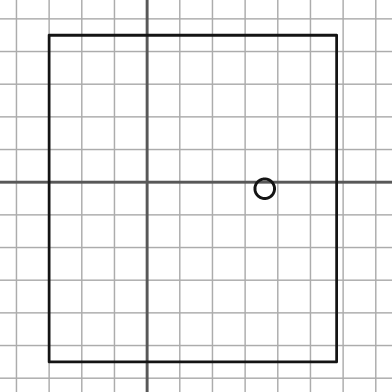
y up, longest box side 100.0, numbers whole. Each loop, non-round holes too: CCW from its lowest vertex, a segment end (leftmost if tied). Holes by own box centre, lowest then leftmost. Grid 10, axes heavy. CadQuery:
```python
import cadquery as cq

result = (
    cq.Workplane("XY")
    .moveTo(-30.0, -55.0)
    .lineTo(58.0, -55.0)
    .lineTo(58.0, 45.0)
    .lineTo(-30.0, 45.0)
    .close()
    .moveTo(36.0, -2.0)
    .circle(3.0)
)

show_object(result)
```